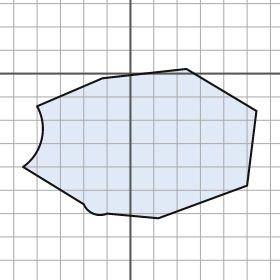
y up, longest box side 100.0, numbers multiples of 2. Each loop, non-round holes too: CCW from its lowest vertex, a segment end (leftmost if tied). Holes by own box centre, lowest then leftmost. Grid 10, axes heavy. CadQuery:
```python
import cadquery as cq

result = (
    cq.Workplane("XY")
    .moveTo(12.0, -62.0)
    .lineTo(50.0, -48.0)
    .lineTo(54.0, -16.0)
    .lineTo(24.0, 2.0)
    .lineTo(-12.0, -2.0)
    .lineTo(-40.0, -14.0)
    .threePointArc((-38.0, -28.0), (-46.0, -40.0))
    .lineTo(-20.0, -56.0)
    .threePointArc((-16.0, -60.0), (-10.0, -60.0))
    .close()
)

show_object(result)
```